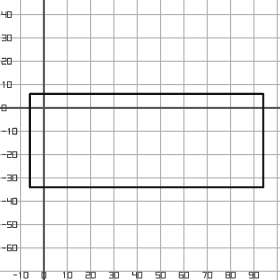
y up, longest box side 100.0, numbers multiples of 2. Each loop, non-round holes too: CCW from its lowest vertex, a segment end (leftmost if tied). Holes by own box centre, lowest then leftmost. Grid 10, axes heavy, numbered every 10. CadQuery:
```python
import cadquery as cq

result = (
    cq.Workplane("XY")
    .moveTo(-6.0, -34.0)
    .lineTo(94.0, -34.0)
    .lineTo(94.0, 6.0)
    .lineTo(-6.0, 6.0)
    .close()
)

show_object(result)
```